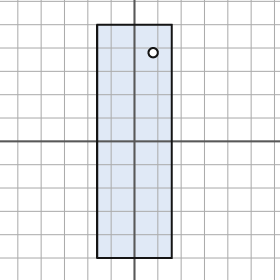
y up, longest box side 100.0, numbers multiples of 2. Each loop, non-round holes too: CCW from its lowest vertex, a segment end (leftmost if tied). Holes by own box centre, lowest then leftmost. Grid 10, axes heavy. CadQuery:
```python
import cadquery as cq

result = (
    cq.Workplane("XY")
    .moveTo(-16.0, -50.0)
    .lineTo(16.0, -50.0)
    .lineTo(16.0, 50.0)
    .lineTo(-16.0, 50.0)
    .close()
    .moveTo(8.0, 38.0)
    .circle(2.0)
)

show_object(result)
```